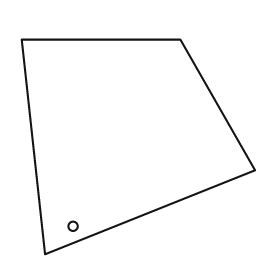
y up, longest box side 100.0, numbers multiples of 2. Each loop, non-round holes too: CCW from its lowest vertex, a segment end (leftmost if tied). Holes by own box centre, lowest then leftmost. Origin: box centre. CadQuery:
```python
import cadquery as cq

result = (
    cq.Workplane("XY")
    .moveTo(-40.0, -46.0)
    .lineTo(50.0, -10.0)
    .lineTo(18.0, 46.0)
    .lineTo(-50.0, 46.0)
    .close()
    .moveTo(-28.0, -34.0)
    .circle(2.0)
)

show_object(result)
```